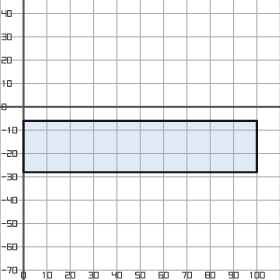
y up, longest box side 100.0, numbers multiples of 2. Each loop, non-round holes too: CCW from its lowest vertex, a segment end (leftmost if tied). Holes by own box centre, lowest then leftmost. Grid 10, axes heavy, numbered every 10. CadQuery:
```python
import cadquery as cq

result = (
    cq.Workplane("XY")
    .moveTo(0.0, -28.0)
    .lineTo(100.0, -28.0)
    .lineTo(100.0, -6.0)
    .lineTo(0.0, -6.0)
    .close()
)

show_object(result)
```